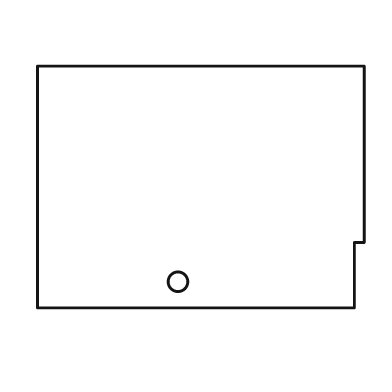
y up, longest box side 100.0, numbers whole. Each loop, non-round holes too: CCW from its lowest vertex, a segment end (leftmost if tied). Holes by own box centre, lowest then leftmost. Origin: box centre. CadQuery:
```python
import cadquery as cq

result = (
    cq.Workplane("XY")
    .moveTo(-50.0, -37.0)
    .lineTo(47.0, -37.0)
    .lineTo(47.0, -17.0)
    .lineTo(50.0, -17.0)
    .lineTo(50.0, 37.0)
    .lineTo(-50.0, 37.0)
    .close()
    .moveTo(-7.0, -29.0)
    .circle(3.0)
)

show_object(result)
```